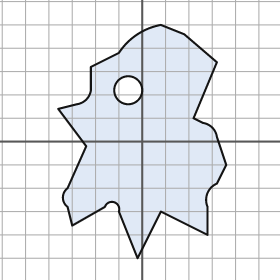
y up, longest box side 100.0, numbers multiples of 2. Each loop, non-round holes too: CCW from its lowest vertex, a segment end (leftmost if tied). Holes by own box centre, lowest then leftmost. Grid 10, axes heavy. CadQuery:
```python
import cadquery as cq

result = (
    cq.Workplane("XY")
    .moveTo(-2.0, -50.0)
    .lineTo(8.0, -30.0)
    .lineTo(28.0, -40.0)
    .lineTo(28.0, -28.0)
    .threePointArc((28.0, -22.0), (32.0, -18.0))
    .lineTo(36.0, -10.0)
    .lineTo(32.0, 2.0)
    .threePointArc((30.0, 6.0), (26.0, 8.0))
    .lineTo(22.0, 10.0)
    .lineTo(32.0, 34.0)
    .lineTo(18.0, 46.0)
    .lineTo(8.0, 50.0)
    .threePointArc((-2.0, 46.0), (-10.0, 38.0))
    .lineTo(-22.0, 32.0)
    .lineTo(-22.0, 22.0)
    .threePointArc((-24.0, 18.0), (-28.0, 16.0))
    .lineTo(-36.0, 14.0)
    .lineTo(-24.0, -2.0)
    .lineTo(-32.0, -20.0)
    .threePointArc((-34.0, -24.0), (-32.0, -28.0))
    .lineTo(-30.0, -36.0)
    .lineTo(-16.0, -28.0)
    .threePointArc((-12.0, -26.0), (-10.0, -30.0))
    .close()
    .moveTo(-6.0, 22.0)
    .circle(6.0)
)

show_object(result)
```